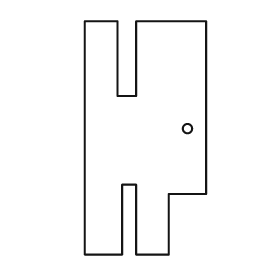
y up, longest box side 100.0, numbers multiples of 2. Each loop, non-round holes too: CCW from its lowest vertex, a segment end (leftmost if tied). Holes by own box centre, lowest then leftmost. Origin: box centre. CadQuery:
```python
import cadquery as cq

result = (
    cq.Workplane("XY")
    .moveTo(-26.0, -50.0)
    .lineTo(-10.0, -50.0)
    .lineTo(-10.0, -20.0)
    .lineTo(-4.0, -20.0)
    .lineTo(-4.0, -50.0)
    .lineTo(10.0, -50.0)
    .lineTo(10.0, -24.0)
    .lineTo(26.0, -24.0)
    .lineTo(26.0, 50.0)
    .lineTo(-4.0, 50.0)
    .lineTo(-4.0, 18.0)
    .lineTo(-12.0, 18.0)
    .lineTo(-12.0, 50.0)
    .lineTo(-26.0, 50.0)
    .close()
    .moveTo(18.0, 4.0)
    .circle(2.0)
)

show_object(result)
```